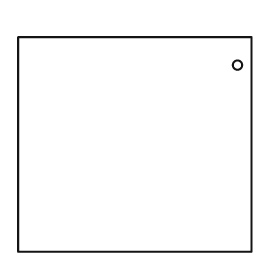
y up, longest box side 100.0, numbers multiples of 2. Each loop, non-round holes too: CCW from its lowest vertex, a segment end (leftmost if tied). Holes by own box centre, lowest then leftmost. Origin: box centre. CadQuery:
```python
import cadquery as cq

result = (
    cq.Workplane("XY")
    .moveTo(-50.0, -46.0)
    .lineTo(50.0, -46.0)
    .lineTo(50.0, 46.0)
    .lineTo(-50.0, 46.0)
    .close()
    .moveTo(44.0, 34.0)
    .circle(2.0)
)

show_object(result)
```